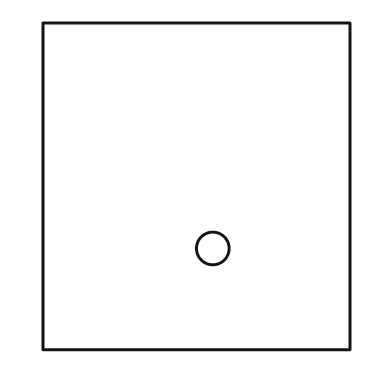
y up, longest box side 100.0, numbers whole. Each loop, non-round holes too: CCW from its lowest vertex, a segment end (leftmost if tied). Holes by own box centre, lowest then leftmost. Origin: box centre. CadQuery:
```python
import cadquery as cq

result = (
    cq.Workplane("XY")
    .moveTo(-47.0, -50.0)
    .lineTo(47.0, -50.0)
    .lineTo(47.0, 50.0)
    .lineTo(-47.0, 50.0)
    .close()
    .moveTo(5.0, -19.0)
    .circle(5.0)
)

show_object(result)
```